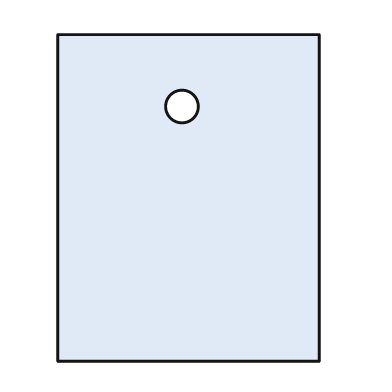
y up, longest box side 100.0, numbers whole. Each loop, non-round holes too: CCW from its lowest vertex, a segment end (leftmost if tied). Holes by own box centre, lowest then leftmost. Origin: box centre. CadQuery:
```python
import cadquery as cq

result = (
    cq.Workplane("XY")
    .moveTo(-40.0, -50.0)
    .lineTo(40.0, -50.0)
    .lineTo(40.0, 50.0)
    .lineTo(-40.0, 50.0)
    .close()
    .moveTo(-2.0, 28.0)
    .circle(5.0)
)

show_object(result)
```